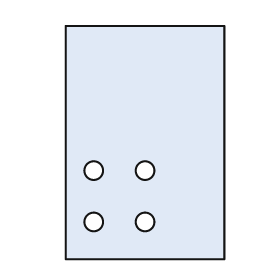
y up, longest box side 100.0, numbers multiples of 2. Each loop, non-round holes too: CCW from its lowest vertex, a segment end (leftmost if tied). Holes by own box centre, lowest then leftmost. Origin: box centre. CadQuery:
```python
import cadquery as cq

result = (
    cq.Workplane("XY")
    .moveTo(-34.0, -50.0)
    .lineTo(34.0, -50.0)
    .lineTo(34.0, 50.0)
    .lineTo(-34.0, 50.0)
    .close()
    .moveTo(-22.0, -34.0)
    .circle(4.0)
    .moveTo(0.0, -34.0)
    .circle(4.0)
    .moveTo(-22.0, -12.0)
    .circle(4.0)
    .moveTo(0.0, -12.0)
    .circle(4.0)
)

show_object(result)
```